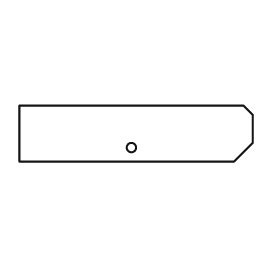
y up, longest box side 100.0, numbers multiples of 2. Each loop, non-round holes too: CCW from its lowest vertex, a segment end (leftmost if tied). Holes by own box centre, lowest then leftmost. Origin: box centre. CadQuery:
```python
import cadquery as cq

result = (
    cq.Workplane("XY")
    .moveTo(-50.0, -12.0)
    .lineTo(42.0, -12.0)
    .lineTo(50.0, -4.0)
    .lineTo(50.0, 8.0)
    .lineTo(46.0, 12.0)
    .lineTo(-50.0, 12.0)
    .close()
    .moveTo(-2.0, -6.0)
    .circle(2.0)
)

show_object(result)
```